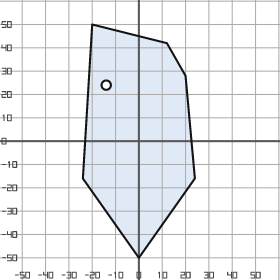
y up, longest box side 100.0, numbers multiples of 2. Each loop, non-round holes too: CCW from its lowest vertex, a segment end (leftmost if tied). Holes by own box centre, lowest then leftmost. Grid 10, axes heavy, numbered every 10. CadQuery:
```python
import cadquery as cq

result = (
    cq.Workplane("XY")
    .moveTo(0.0, -50.0)
    .lineTo(24.0, -16.0)
    .lineTo(20.0, 28.0)
    .lineTo(12.0, 42.0)
    .lineTo(-20.0, 50.0)
    .lineTo(-24.0, -16.0)
    .close()
    .moveTo(-14.0, 24.0)
    .circle(2.0)
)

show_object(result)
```